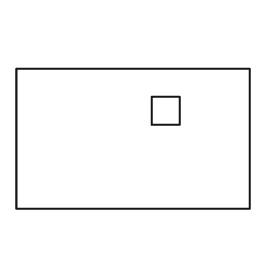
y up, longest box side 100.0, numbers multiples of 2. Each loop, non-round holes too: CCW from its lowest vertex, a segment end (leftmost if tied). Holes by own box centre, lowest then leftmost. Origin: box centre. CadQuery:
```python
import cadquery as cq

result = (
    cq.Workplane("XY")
    .moveTo(-50.0, -30.0)
    .lineTo(50.0, -30.0)
    .lineTo(50.0, 30.0)
    .lineTo(-50.0, 30.0)
    .close()
    .moveTo(8.0, 6.0)
    .lineTo(20.0, 6.0)
    .lineTo(20.0, 18.0)
    .lineTo(8.0, 18.0)
    .close()
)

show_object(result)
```